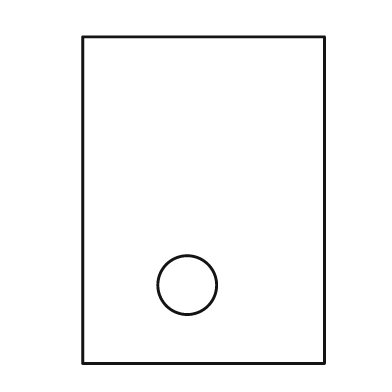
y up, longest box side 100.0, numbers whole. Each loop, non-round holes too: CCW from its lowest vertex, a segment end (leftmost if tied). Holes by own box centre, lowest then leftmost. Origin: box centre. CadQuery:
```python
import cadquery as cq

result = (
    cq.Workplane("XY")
    .moveTo(-37.0, -50.0)
    .lineTo(37.0, -50.0)
    .lineTo(37.0, 50.0)
    .lineTo(-37.0, 50.0)
    .close()
    .moveTo(-5.0, -26.0)
    .circle(9.0)
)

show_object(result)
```